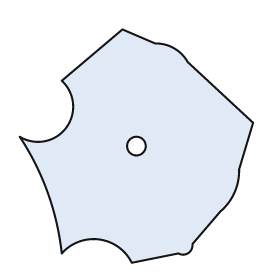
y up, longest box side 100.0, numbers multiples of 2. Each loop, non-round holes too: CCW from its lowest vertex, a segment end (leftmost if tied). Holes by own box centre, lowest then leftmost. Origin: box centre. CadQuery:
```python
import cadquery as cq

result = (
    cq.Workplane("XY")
    .moveTo(-2.0, -50.0)
    .lineTo(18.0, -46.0)
    .threePointArc((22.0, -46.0), (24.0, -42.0))
    .lineTo(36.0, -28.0)
    .threePointArc((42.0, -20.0), (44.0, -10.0))
    .lineTo(50.0, 10.0)
    .lineTo(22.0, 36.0)
    .threePointArc((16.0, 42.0), (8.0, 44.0))
    .lineTo(-6.0, 50.0)
    .lineTo(-32.0, 28.0)
    .threePointArc((-30.0, 8.0), (-50.0, 4.0))
    .threePointArc((-38.0, -20.0), (-32.0, -46.0))
    .threePointArc((-16.0, -40.0), (-2.0, -50.0))
    .close()
    .moveTo(0.0, 0.0)
    .circle(4.0)
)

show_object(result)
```